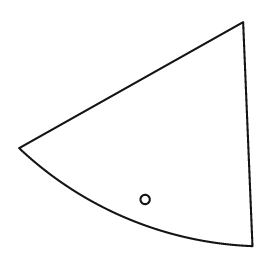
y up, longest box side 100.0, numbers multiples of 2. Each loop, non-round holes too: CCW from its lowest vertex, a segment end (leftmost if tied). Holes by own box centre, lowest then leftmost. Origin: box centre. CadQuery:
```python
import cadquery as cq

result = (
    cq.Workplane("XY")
    .moveTo(50.0, -48.0)
    .lineTo(46.0, 48.0)
    .lineTo(-50.0, -6.0)
    .threePointArc((-4.0, -36.0), (50.0, -48.0))
    .close()
    .moveTo(4.0, -28.0)
    .circle(2.0)
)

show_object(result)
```